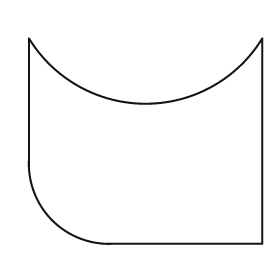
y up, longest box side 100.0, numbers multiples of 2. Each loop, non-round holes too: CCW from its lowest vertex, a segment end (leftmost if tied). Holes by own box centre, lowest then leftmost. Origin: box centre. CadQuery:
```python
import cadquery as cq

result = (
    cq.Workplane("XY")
    .moveTo(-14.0, -44.0)
    .lineTo(50.0, -44.0)
    .lineTo(50.0, 44.0)
    .threePointArc((0.0, 16.0), (-50.0, 44.0))
    .lineTo(-50.0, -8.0)
    .threePointArc((-40.0, -34.0), (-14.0, -44.0))
    .close()
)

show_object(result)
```